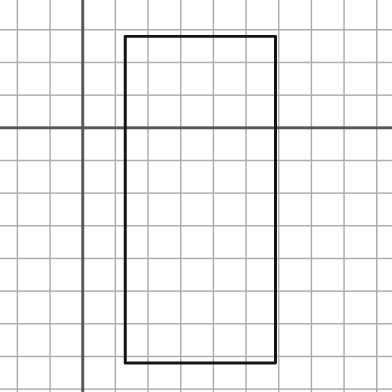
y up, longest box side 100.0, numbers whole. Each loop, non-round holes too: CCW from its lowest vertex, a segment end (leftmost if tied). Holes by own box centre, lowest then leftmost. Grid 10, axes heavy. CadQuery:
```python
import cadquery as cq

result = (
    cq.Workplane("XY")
    .moveTo(13.0, -72.0)
    .lineTo(59.0, -72.0)
    .lineTo(59.0, 28.0)
    .lineTo(13.0, 28.0)
    .close()
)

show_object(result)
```